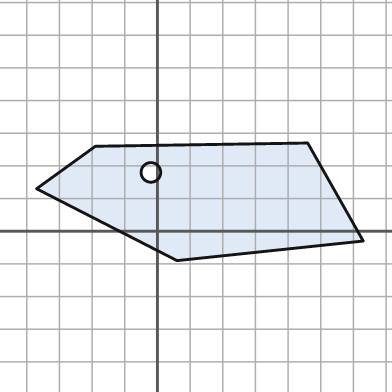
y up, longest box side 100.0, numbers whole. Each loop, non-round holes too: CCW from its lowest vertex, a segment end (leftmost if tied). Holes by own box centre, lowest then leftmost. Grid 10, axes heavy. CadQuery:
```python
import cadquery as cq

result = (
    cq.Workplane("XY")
    .moveTo(6.0, -9.0)
    .lineTo(63.0, -3.0)
    .lineTo(46.0, 27.0)
    .lineTo(-19.0, 26.0)
    .lineTo(-37.0, 13.0)
    .close()
    .moveTo(-2.0, 18.0)
    .circle(3.0)
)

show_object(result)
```